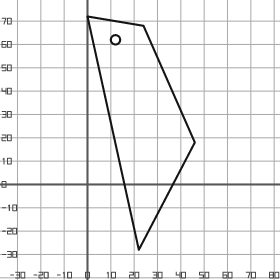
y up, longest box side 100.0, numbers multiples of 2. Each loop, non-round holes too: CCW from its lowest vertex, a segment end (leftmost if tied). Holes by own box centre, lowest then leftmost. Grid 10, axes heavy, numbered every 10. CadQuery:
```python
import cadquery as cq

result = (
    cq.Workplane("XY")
    .moveTo(22.0, -28.0)
    .lineTo(46.0, 18.0)
    .lineTo(24.0, 68.0)
    .lineTo(0.0, 72.0)
    .close()
    .moveTo(12.0, 62.0)
    .circle(2.0)
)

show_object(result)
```